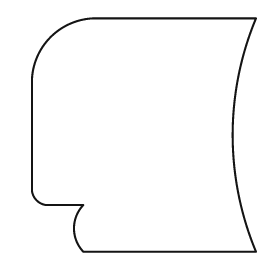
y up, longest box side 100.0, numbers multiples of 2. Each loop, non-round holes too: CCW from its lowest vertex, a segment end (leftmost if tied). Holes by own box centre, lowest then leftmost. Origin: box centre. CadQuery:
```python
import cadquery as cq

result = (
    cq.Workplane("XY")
    .moveTo(-26.0, -50.0)
    .lineTo(48.0, -50.0)
    .threePointArc((38.0, 0.0), (48.0, 50.0))
    .lineTo(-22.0, 50.0)
    .threePointArc((-40.0, 42.0), (-48.0, 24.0))
    .lineTo(-48.0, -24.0)
    .threePointArc((-46.0, -28.0), (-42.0, -30.0))
    .lineTo(-26.0, -30.0)
    .threePointArc((-30.0, -40.0), (-26.0, -50.0))
    .close()
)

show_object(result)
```